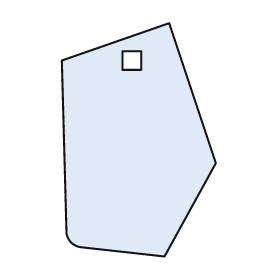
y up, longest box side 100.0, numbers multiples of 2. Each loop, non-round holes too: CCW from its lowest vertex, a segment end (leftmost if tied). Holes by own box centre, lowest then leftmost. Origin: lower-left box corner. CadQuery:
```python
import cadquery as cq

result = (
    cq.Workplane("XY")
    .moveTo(44.0, 0.0)
    .lineTo(66.0, 40.0)
    .lineTo(46.0, 100.0)
    .lineTo(0.0, 84.0)
    .lineTo(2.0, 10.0)
    .threePointArc((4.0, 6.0), (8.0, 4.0))
    .close()
    .moveTo(26.0, 80.0)
    .lineTo(34.0, 80.0)
    .lineTo(34.0, 88.0)
    .lineTo(26.0, 88.0)
    .close()
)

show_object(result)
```